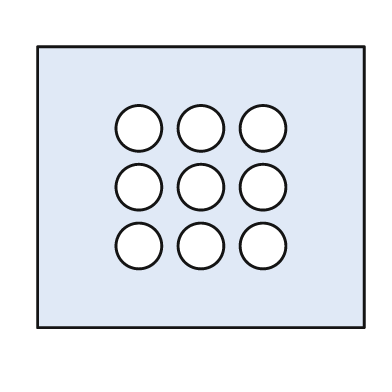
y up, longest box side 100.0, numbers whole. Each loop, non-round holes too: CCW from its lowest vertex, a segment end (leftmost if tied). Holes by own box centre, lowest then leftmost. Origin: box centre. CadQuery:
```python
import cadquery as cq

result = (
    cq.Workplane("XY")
    .moveTo(-50.0, -43.0)
    .lineTo(50.0, -43.0)
    .lineTo(50.0, 43.0)
    .lineTo(-50.0, 43.0)
    .close()
    .moveTo(-19.0, -18.0)
    .circle(7.0)
    .moveTo(0.0, -18.0)
    .circle(7.0)
    .moveTo(19.0, -18.0)
    .circle(7.0)
    .moveTo(-19.0, 0.0)
    .circle(7.0)
    .moveTo(0.0, 0.0)
    .circle(7.0)
    .moveTo(19.0, 0.0)
    .circle(7.0)
    .moveTo(-19.0, 18.0)
    .circle(7.0)
    .moveTo(0.0, 18.0)
    .circle(7.0)
    .moveTo(19.0, 18.0)
    .circle(7.0)
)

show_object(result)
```